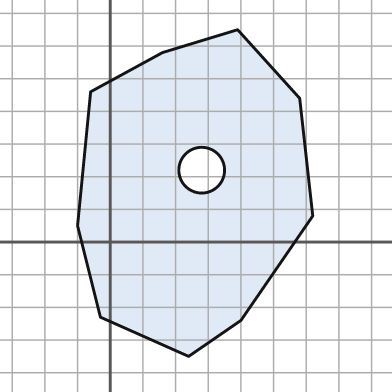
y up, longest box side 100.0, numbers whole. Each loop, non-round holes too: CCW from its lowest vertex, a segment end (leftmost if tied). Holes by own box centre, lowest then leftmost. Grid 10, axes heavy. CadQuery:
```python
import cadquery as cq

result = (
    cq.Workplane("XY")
    .moveTo(24.0, -35.0)
    .lineTo(40.0, -24.0)
    .lineTo(62.0, 8.0)
    .lineTo(58.0, 44.0)
    .lineTo(39.0, 65.0)
    .lineTo(16.0, 58.0)
    .lineTo(-6.0, 46.0)
    .lineTo(-10.0, 5.0)
    .lineTo(-3.0, -23.0)
    .close()
    .moveTo(28.0, 22.0)
    .circle(7.0)
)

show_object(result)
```